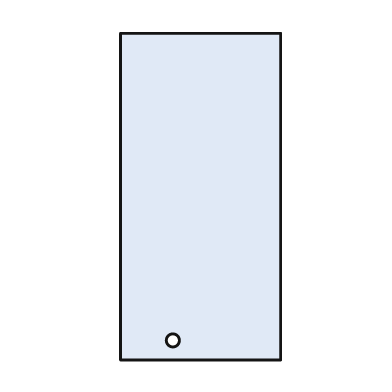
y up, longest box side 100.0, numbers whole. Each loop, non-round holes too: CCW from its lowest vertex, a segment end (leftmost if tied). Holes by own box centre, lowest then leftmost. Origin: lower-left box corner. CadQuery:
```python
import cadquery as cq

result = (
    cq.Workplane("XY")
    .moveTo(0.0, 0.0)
    .lineTo(49.0, 0.0)
    .lineTo(49.0, 100.0)
    .lineTo(0.0, 100.0)
    .close()
    .moveTo(16.0, 6.0)
    .circle(2.0)
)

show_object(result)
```